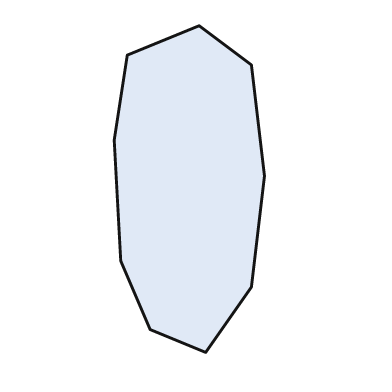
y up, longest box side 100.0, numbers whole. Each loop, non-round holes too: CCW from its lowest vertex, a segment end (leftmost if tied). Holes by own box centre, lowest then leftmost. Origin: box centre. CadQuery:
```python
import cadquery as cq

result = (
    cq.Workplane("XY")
    .moveTo(5.0, -50.0)
    .lineTo(19.0, -30.0)
    .lineTo(23.0, 4.0)
    .lineTo(19.0, 38.0)
    .lineTo(3.0, 50.0)
    .lineTo(-19.0, 41.0)
    .lineTo(-23.0, 15.0)
    .lineTo(-21.0, -22.0)
    .lineTo(-12.0, -43.0)
    .close()
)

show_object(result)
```